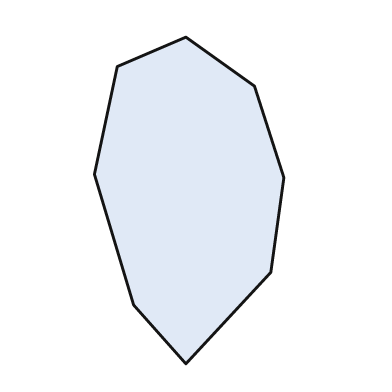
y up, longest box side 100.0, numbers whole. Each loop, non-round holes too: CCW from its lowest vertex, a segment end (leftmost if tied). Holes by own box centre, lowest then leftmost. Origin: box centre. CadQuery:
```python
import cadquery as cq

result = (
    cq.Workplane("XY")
    .moveTo(-1.0, -50.0)
    .lineTo(25.0, -22.0)
    .lineTo(29.0, 7.0)
    .lineTo(20.0, 35.0)
    .lineTo(-1.0, 50.0)
    .lineTo(-22.0, 41.0)
    .lineTo(-29.0, 8.0)
    .lineTo(-17.0, -32.0)
    .close()
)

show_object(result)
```